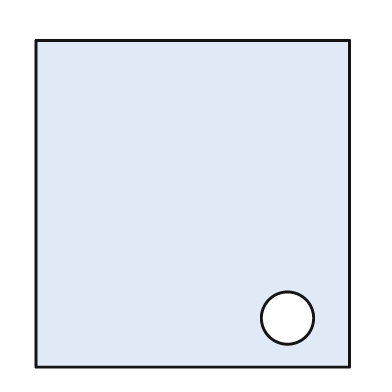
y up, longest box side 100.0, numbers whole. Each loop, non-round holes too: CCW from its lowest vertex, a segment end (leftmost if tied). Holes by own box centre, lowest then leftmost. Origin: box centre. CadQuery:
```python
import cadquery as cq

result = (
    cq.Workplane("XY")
    .moveTo(-48.0, -50.0)
    .lineTo(48.0, -50.0)
    .lineTo(48.0, 50.0)
    .lineTo(-48.0, 50.0)
    .close()
    .moveTo(29.0, -35.0)
    .circle(8.0)
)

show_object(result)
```